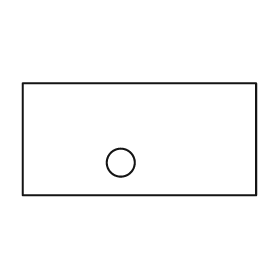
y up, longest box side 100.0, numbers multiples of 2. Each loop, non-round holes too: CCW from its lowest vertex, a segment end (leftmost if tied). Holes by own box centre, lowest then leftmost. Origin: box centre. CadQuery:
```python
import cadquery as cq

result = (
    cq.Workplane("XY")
    .moveTo(-50.0, -24.0)
    .lineTo(50.0, -24.0)
    .lineTo(50.0, 24.0)
    .lineTo(-50.0, 24.0)
    .close()
    .moveTo(-8.0, -10.0)
    .circle(6.0)
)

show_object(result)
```